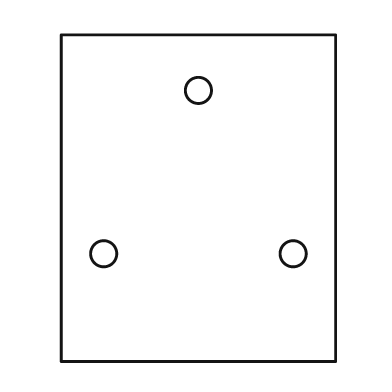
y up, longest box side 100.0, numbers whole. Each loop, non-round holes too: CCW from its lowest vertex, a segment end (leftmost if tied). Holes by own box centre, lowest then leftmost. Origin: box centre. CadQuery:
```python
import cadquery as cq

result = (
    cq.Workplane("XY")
    .moveTo(-42.0, -50.0)
    .lineTo(42.0, -50.0)
    .lineTo(42.0, 50.0)
    .lineTo(-42.0, 50.0)
    .close()
    .moveTo(-29.0, -17.0)
    .circle(4.0)
    .moveTo(29.0, -17.0)
    .circle(4.0)
    .moveTo(0.0, 33.0)
    .circle(4.0)
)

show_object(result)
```